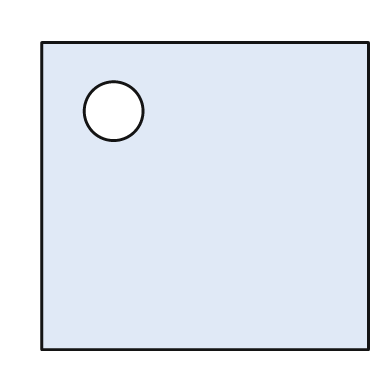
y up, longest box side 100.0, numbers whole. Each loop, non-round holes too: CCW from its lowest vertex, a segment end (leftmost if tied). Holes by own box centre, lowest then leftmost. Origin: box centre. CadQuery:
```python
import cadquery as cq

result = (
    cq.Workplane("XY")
    .moveTo(-50.0, -47.0)
    .lineTo(50.0, -47.0)
    .lineTo(50.0, 47.0)
    .lineTo(-50.0, 47.0)
    .close()
    .moveTo(-28.0, 26.0)
    .circle(9.0)
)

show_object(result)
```